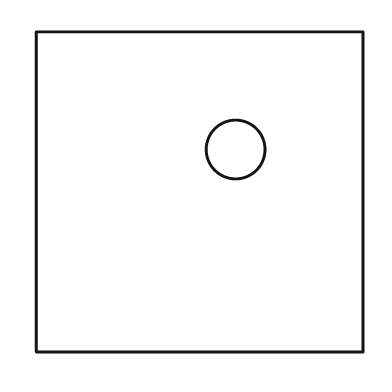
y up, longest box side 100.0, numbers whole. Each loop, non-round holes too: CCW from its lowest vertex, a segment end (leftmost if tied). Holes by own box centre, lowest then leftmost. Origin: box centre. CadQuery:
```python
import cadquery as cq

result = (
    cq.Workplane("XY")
    .moveTo(-50.0, -49.0)
    .lineTo(50.0, -49.0)
    .lineTo(50.0, 49.0)
    .lineTo(-50.0, 49.0)
    .close()
    .moveTo(11.0, 13.0)
    .circle(9.0)
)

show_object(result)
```